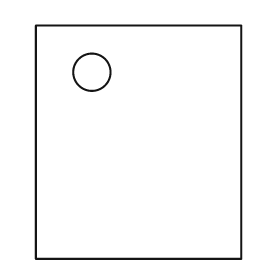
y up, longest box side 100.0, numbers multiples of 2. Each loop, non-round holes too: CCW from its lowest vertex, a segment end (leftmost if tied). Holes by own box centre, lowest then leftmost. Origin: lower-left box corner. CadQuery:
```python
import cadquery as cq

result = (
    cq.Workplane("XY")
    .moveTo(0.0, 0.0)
    .lineTo(88.0, 0.0)
    .lineTo(88.0, 100.0)
    .lineTo(0.0, 100.0)
    .close()
    .moveTo(24.0, 80.0)
    .circle(8.0)
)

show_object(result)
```